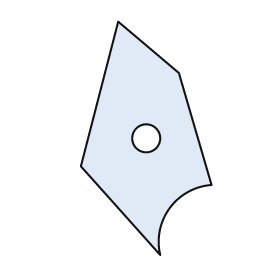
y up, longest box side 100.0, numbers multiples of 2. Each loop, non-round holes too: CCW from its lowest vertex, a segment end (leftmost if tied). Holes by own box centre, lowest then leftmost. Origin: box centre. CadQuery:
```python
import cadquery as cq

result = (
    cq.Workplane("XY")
    .moveTo(6.0, -50.0)
    .threePointArc((10.0, -30.0), (28.0, -20.0))
    .lineTo(14.0, 28.0)
    .lineTo(-12.0, 50.0)
    .lineTo(-28.0, -12.0)
    .close()
    .moveTo(0.0, 0.0)
    .circle(6.0)
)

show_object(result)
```